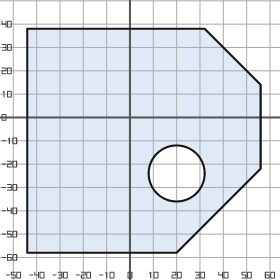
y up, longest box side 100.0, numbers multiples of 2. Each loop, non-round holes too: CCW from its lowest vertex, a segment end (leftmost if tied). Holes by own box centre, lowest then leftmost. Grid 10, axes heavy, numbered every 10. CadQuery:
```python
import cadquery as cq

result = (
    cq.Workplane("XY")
    .moveTo(-44.0, -58.0)
    .lineTo(20.0, -58.0)
    .lineTo(56.0, -22.0)
    .lineTo(56.0, 14.0)
    .lineTo(32.0, 38.0)
    .lineTo(-44.0, 38.0)
    .close()
    .moveTo(20.0, -24.0)
    .circle(12.0)
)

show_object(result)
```